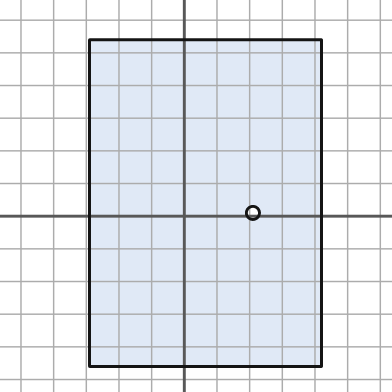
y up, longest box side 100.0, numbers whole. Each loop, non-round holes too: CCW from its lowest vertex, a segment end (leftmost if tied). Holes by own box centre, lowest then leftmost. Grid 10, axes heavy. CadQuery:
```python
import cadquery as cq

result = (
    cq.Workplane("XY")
    .moveTo(-29.0, -46.0)
    .lineTo(42.0, -46.0)
    .lineTo(42.0, 54.0)
    .lineTo(-29.0, 54.0)
    .close()
    .moveTo(21.0, 1.0)
    .circle(2.0)
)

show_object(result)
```